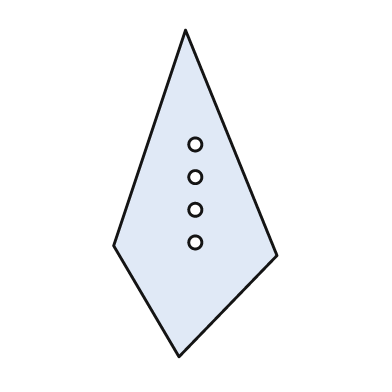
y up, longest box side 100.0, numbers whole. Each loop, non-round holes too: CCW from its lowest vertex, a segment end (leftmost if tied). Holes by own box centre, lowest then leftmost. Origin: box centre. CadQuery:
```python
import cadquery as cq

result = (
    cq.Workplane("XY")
    .moveTo(-5.0, -50.0)
    .lineTo(25.0, -19.0)
    .lineTo(-3.0, 50.0)
    .lineTo(-25.0, -16.0)
    .close()
    .moveTo(0.0, -15.0)
    .circle(2.0)
    .moveTo(0.0, -5.0)
    .circle(2.0)
    .moveTo(0.0, 5.0)
    .circle(2.0)
    .moveTo(0.0, 15.0)
    .circle(2.0)
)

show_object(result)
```